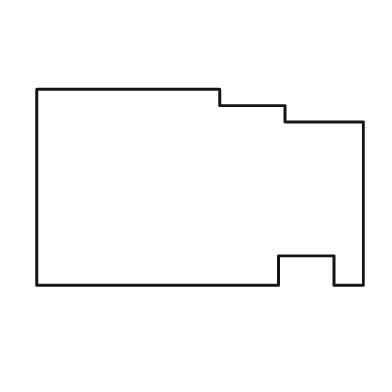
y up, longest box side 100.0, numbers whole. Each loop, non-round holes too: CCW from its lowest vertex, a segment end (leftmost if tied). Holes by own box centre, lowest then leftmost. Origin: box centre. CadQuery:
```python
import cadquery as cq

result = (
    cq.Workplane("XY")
    .moveTo(-50.0, -30.0)
    .lineTo(24.0, -30.0)
    .lineTo(24.0, -21.0)
    .lineTo(41.0, -21.0)
    .lineTo(41.0, -30.0)
    .lineTo(50.0, -30.0)
    .lineTo(50.0, 20.0)
    .lineTo(26.0, 20.0)
    .lineTo(26.0, 25.0)
    .lineTo(6.0, 25.0)
    .lineTo(6.0, 30.0)
    .lineTo(-50.0, 30.0)
    .close()
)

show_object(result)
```